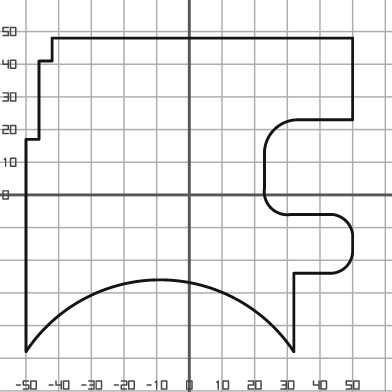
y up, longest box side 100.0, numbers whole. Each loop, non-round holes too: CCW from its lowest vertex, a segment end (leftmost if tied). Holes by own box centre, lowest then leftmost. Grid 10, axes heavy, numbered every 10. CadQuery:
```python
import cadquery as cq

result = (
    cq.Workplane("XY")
    .moveTo(-50.0, -48.0)
    .threePointArc((-9.0, -26.0), (32.0, -48.0))
    .lineTo(32.0, -24.0)
    .lineTo(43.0, -24.0)
    .threePointArc((48.0, -22.0), (50.0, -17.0))
    .lineTo(50.0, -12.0)
    .threePointArc((48.0, -8.0), (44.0, -6.0))
    .lineTo(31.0, -6.0)
    .threePointArc((25.0, -4.0), (23.0, 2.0))
    .lineTo(23.0, 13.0)
    .threePointArc((26.0, 20.0), (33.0, 23.0))
    .lineTo(50.0, 23.0)
    .lineTo(50.0, 48.0)
    .lineTo(-42.0, 48.0)
    .lineTo(-42.0, 41.0)
    .lineTo(-46.0, 41.0)
    .lineTo(-46.0, 17.0)
    .lineTo(-50.0, 17.0)
    .close()
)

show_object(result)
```